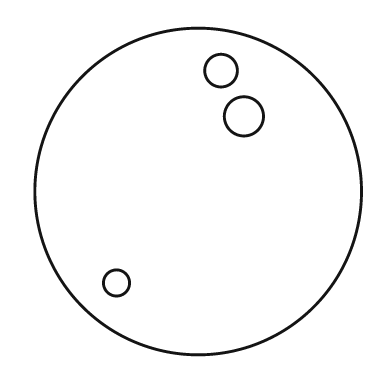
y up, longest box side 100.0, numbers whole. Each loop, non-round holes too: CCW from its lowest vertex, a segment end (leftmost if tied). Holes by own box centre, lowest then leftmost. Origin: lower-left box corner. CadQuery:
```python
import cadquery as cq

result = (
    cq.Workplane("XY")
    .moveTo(50.0, 50.0)
    .circle(50.0)
    .moveTo(25.0, 22.0)
    .circle(4.0)
    .moveTo(64.0, 73.0)
    .circle(6.0)
    .moveTo(57.0, 87.0)
    .circle(5.0)
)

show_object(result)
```